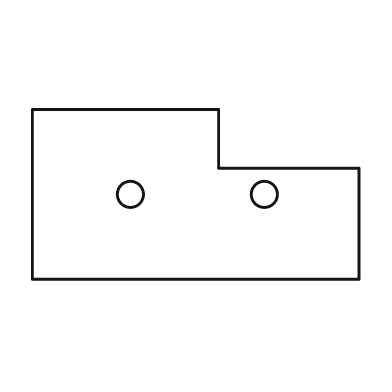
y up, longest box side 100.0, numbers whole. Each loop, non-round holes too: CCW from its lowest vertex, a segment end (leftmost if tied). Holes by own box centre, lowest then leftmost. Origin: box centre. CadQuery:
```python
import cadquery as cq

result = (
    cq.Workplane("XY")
    .moveTo(-50.0, -26.0)
    .lineTo(50.0, -26.0)
    .lineTo(50.0, 8.0)
    .lineTo(7.0, 8.0)
    .lineTo(7.0, 26.0)
    .lineTo(-50.0, 26.0)
    .close()
    .moveTo(-20.0, 0.0)
    .circle(4.0)
    .moveTo(21.0, 0.0)
    .circle(4.0)
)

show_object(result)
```